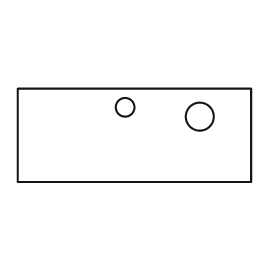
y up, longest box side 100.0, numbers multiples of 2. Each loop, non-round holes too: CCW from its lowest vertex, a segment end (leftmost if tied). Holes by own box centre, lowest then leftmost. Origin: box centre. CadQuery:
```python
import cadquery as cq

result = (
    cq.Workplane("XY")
    .moveTo(-50.0, -20.0)
    .lineTo(50.0, -20.0)
    .lineTo(50.0, 20.0)
    .lineTo(-50.0, 20.0)
    .close()
    .moveTo(28.0, 8.0)
    .circle(6.0)
    .moveTo(-4.0, 12.0)
    .circle(4.0)
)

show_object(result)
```